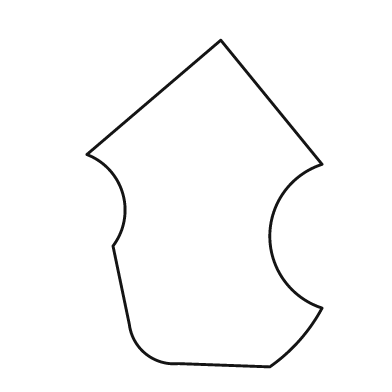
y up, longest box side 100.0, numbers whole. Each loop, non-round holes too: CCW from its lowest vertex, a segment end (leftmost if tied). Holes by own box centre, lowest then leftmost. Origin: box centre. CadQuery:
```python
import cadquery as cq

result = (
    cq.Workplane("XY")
    .moveTo(20.0, -50.0)
    .threePointArc((29.0, -42.0), (36.0, -32.0))
    .threePointArc((20.0, -10.0), (36.0, 12.0))
    .lineTo(5.0, 50.0)
    .lineTo(-36.0, 15.0)
    .threePointArc((-25.0, 3.0), (-28.0, -13.0))
    .lineTo(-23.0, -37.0)
    .threePointArc((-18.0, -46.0), (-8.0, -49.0))
    .close()
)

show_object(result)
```